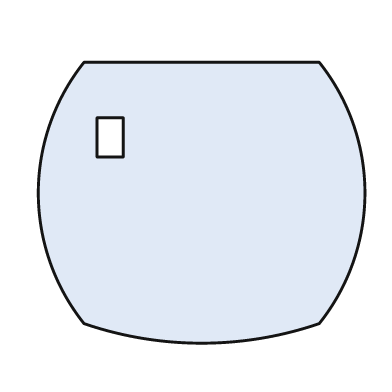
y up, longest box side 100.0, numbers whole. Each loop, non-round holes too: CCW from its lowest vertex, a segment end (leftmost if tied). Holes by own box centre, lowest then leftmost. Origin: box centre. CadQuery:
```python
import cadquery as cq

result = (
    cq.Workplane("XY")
    .moveTo(-36.0, -37.0)
    .threePointArc((0.0, -43.0), (36.0, -37.0))
    .threePointArc((50.0, 3.0), (36.0, 43.0))
    .lineTo(-36.0, 43.0)
    .threePointArc((-50.0, 3.0), (-36.0, -37.0))
    .close()
    .moveTo(-32.0, 14.0)
    .lineTo(-24.0, 14.0)
    .lineTo(-24.0, 26.0)
    .lineTo(-32.0, 26.0)
    .close()
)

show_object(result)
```